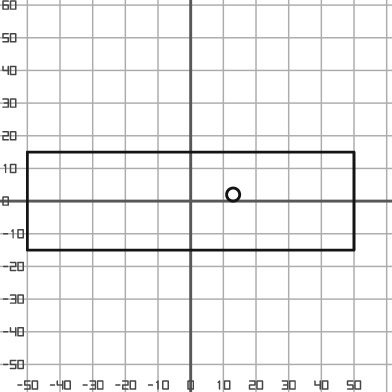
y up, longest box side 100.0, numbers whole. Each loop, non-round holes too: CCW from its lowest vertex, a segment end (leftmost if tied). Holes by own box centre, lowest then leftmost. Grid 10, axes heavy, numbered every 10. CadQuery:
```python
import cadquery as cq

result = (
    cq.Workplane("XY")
    .moveTo(-50.0, -15.0)
    .lineTo(50.0, -15.0)
    .lineTo(50.0, 15.0)
    .lineTo(-50.0, 15.0)
    .close()
    .moveTo(13.0, 2.0)
    .circle(2.0)
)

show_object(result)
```